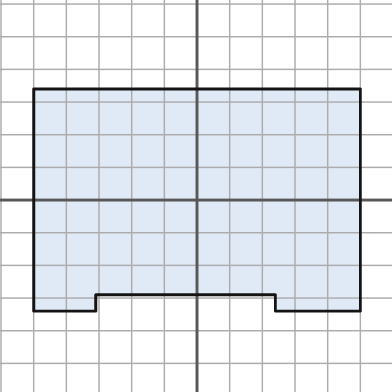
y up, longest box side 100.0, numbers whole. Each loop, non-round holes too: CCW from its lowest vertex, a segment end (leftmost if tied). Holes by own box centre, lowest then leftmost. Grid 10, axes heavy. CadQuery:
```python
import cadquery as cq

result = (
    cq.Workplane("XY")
    .moveTo(-50.0, -34.0)
    .lineTo(-31.0, -34.0)
    .lineTo(-31.0, -29.0)
    .lineTo(24.0, -29.0)
    .lineTo(24.0, -34.0)
    .lineTo(50.0, -34.0)
    .lineTo(50.0, 34.0)
    .lineTo(-50.0, 34.0)
    .close()
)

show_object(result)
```